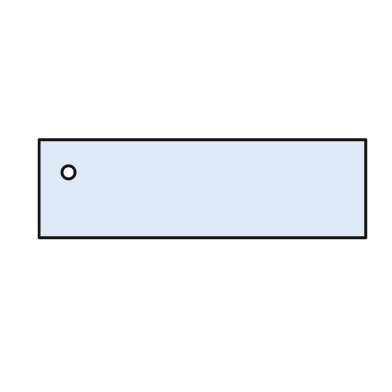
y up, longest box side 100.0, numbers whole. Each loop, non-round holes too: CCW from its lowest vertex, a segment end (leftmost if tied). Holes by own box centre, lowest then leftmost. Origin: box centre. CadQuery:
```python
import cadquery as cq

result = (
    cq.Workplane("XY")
    .moveTo(-50.0, -15.0)
    .lineTo(50.0, -15.0)
    .lineTo(50.0, 15.0)
    .lineTo(-50.0, 15.0)
    .close()
    .moveTo(-41.0, 5.0)
    .circle(2.0)
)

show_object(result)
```